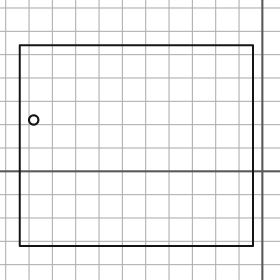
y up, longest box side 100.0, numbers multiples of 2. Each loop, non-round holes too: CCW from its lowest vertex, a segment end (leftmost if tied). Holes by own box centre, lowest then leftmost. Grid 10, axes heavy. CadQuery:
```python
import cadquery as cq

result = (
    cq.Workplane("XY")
    .moveTo(-104.0, -32.0)
    .lineTo(-4.0, -32.0)
    .lineTo(-4.0, 54.0)
    .lineTo(-104.0, 54.0)
    .close()
    .moveTo(-98.0, 22.0)
    .circle(2.0)
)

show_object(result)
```